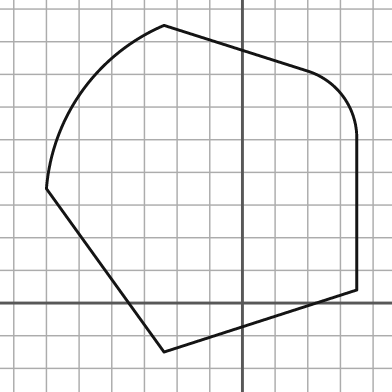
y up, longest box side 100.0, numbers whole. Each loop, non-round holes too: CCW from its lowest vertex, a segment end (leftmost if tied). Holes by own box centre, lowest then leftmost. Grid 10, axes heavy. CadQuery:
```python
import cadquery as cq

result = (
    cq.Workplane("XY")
    .moveTo(-24.0, -15.0)
    .lineTo(35.0, 4.0)
    .lineTo(35.0, 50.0)
    .threePointArc((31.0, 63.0), (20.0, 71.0))
    .lineTo(-24.0, 85.0)
    .threePointArc((-49.0, 65.0), (-60.0, 35.0))
    .close()
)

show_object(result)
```